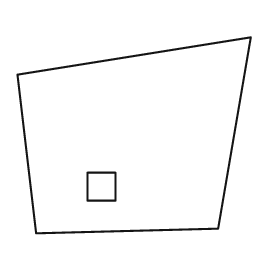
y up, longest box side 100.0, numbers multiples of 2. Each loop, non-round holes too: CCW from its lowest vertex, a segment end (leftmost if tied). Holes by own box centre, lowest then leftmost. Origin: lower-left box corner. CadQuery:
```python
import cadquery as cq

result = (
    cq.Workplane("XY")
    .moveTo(8.0, 0.0)
    .lineTo(86.0, 2.0)
    .lineTo(100.0, 84.0)
    .lineTo(0.0, 68.0)
    .close()
    .moveTo(30.0, 14.0)
    .lineTo(42.0, 14.0)
    .lineTo(42.0, 26.0)
    .lineTo(30.0, 26.0)
    .close()
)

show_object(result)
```